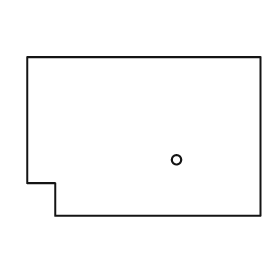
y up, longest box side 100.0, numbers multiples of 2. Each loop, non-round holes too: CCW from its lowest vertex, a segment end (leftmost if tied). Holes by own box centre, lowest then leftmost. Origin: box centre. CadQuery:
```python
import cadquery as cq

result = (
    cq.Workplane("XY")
    .moveTo(-38.0, -34.0)
    .lineTo(50.0, -34.0)
    .lineTo(50.0, 34.0)
    .lineTo(-50.0, 34.0)
    .lineTo(-50.0, -20.0)
    .lineTo(-38.0, -20.0)
    .close()
    .moveTo(14.0, -10.0)
    .circle(2.0)
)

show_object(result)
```